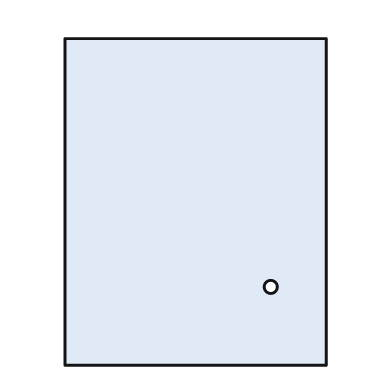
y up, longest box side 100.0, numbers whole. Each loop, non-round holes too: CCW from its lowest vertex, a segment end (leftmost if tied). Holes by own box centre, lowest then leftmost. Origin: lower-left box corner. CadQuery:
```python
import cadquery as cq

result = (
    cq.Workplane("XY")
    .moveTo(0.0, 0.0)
    .lineTo(80.0, 0.0)
    .lineTo(80.0, 100.0)
    .lineTo(0.0, 100.0)
    .close()
    .moveTo(63.0, 24.0)
    .circle(2.0)
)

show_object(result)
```